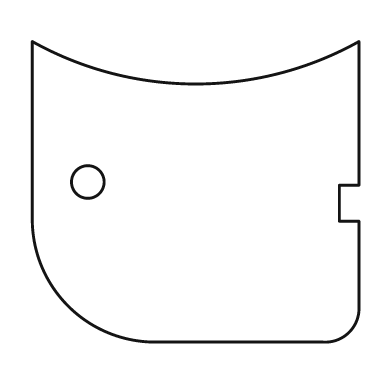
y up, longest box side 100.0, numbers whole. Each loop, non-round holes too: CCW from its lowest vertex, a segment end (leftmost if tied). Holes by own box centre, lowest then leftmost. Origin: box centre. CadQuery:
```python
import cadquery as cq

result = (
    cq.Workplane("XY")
    .moveTo(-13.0, -46.0)
    .lineTo(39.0, -46.0)
    .threePointArc((47.0, -43.0), (50.0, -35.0))
    .lineTo(50.0, -9.0)
    .lineTo(44.0, -9.0)
    .lineTo(44.0, 2.0)
    .lineTo(50.0, 2.0)
    .lineTo(50.0, 46.0)
    .threePointArc((0.0, 33.0), (-50.0, 46.0))
    .lineTo(-50.0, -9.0)
    .threePointArc((-39.0, -35.0), (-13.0, -46.0))
    .close()
    .moveTo(-33.0, 3.0)
    .circle(5.0)
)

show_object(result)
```